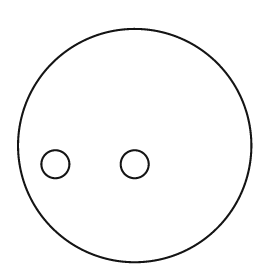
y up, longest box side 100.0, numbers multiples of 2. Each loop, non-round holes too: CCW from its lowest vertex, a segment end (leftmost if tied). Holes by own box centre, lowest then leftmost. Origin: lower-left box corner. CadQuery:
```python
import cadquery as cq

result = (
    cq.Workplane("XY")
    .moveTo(50.0, 50.0)
    .circle(50.0)
    .moveTo(16.0, 42.0)
    .circle(6.0)
    .moveTo(50.0, 42.0)
    .circle(6.0)
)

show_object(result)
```